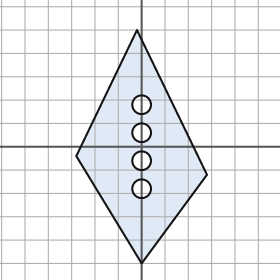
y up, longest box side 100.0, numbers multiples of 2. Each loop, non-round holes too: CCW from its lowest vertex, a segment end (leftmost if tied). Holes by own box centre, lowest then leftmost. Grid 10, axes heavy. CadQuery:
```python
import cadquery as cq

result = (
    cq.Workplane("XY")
    .moveTo(0.0, -50.0)
    .lineTo(28.0, -12.0)
    .lineTo(-2.0, 50.0)
    .lineTo(-28.0, -4.0)
    .close()
    .moveTo(0.0, -18.0)
    .circle(4.0)
    .moveTo(0.0, -6.0)
    .circle(4.0)
    .moveTo(0.0, 6.0)
    .circle(4.0)
    .moveTo(0.0, 18.0)
    .circle(4.0)
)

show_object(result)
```